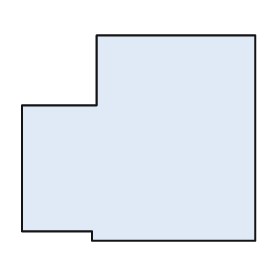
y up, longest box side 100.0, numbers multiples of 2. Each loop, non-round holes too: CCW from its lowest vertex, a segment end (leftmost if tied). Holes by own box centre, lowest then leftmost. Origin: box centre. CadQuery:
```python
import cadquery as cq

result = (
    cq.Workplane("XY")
    .moveTo(-20.0, -44.0)
    .lineTo(50.0, -44.0)
    .lineTo(50.0, 44.0)
    .lineTo(-18.0, 44.0)
    .lineTo(-18.0, 14.0)
    .lineTo(-50.0, 14.0)
    .lineTo(-50.0, -40.0)
    .lineTo(-20.0, -40.0)
    .close()
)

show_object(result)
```